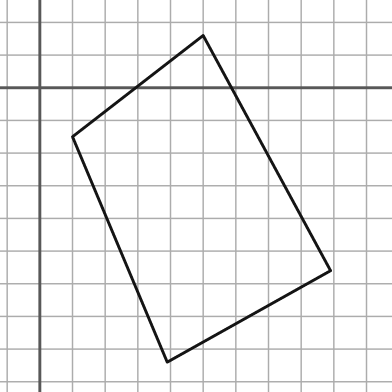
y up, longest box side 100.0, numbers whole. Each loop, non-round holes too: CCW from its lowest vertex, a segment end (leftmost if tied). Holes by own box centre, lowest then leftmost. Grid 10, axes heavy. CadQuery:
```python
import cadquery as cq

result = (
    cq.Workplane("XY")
    .moveTo(39.0, -84.0)
    .lineTo(89.0, -56.0)
    .lineTo(50.0, 16.0)
    .lineTo(10.0, -15.0)
    .close()
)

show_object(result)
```